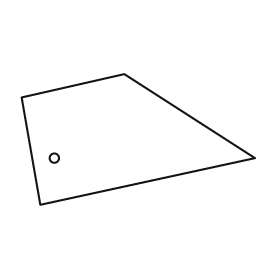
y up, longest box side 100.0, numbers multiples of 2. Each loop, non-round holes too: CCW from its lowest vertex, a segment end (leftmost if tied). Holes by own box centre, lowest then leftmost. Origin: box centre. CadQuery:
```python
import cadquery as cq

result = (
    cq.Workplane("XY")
    .moveTo(-42.0, -28.0)
    .lineTo(50.0, -8.0)
    .lineTo(-6.0, 28.0)
    .lineTo(-50.0, 18.0)
    .close()
    .moveTo(-36.0, -8.0)
    .circle(2.0)
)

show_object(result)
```